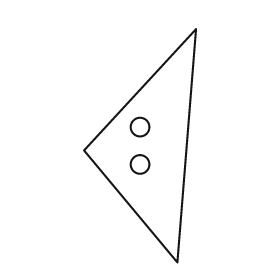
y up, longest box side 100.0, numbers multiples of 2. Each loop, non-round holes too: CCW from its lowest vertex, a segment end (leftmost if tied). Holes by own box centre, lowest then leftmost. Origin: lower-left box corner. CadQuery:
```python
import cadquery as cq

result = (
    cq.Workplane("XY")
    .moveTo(40.0, 0.0)
    .lineTo(48.0, 100.0)
    .lineTo(0.0, 48.0)
    .close()
    .moveTo(24.0, 42.0)
    .circle(4.0)
    .moveTo(24.0, 58.0)
    .circle(4.0)
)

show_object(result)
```